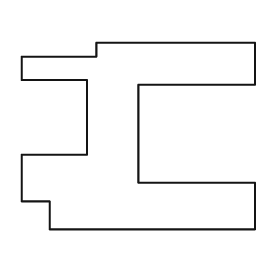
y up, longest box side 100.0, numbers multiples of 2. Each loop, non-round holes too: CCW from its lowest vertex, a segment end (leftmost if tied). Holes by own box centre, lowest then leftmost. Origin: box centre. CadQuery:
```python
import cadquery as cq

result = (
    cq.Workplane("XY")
    .moveTo(-38.0, -40.0)
    .lineTo(50.0, -40.0)
    .lineTo(50.0, -20.0)
    .lineTo(0.0, -20.0)
    .lineTo(0.0, 22.0)
    .lineTo(50.0, 22.0)
    .lineTo(50.0, 40.0)
    .lineTo(-18.0, 40.0)
    .lineTo(-18.0, 34.0)
    .lineTo(-50.0, 34.0)
    .lineTo(-50.0, 24.0)
    .lineTo(-22.0, 24.0)
    .lineTo(-22.0, -8.0)
    .lineTo(-50.0, -8.0)
    .lineTo(-50.0, -28.0)
    .lineTo(-38.0, -28.0)
    .close()
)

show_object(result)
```